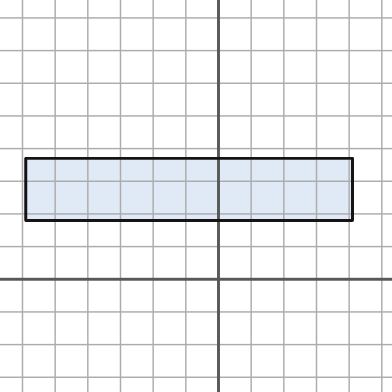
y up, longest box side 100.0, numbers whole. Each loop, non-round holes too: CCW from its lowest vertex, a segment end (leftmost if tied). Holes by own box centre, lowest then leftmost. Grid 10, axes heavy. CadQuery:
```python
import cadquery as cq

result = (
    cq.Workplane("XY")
    .moveTo(-59.0, 18.0)
    .lineTo(41.0, 18.0)
    .lineTo(41.0, 37.0)
    .lineTo(-59.0, 37.0)
    .close()
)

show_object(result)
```